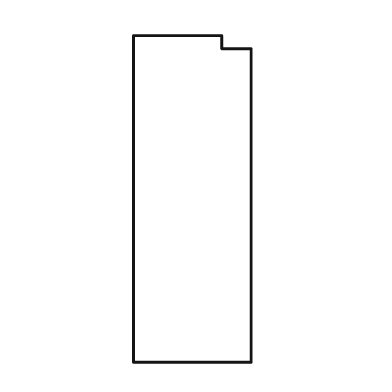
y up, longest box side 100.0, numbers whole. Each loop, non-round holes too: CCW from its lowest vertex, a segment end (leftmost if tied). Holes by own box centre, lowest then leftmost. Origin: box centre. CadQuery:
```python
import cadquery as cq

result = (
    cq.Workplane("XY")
    .moveTo(-18.0, -50.0)
    .lineTo(18.0, -50.0)
    .lineTo(18.0, 46.0)
    .lineTo(9.0, 46.0)
    .lineTo(9.0, 50.0)
    .lineTo(-18.0, 50.0)
    .close()
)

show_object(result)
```